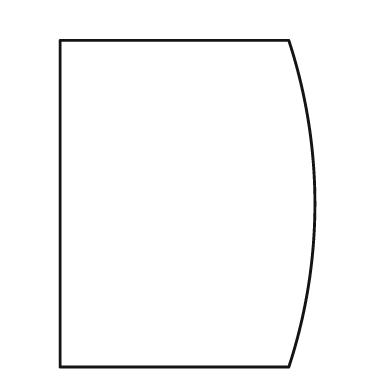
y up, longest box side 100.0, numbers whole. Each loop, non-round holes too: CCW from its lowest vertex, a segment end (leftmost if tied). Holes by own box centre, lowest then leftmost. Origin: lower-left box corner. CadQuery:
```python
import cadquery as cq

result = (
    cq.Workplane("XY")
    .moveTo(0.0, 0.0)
    .lineTo(70.0, 0.0)
    .threePointArc((78.0, 50.0), (70.0, 100.0))
    .lineTo(0.0, 100.0)
    .close()
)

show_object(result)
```